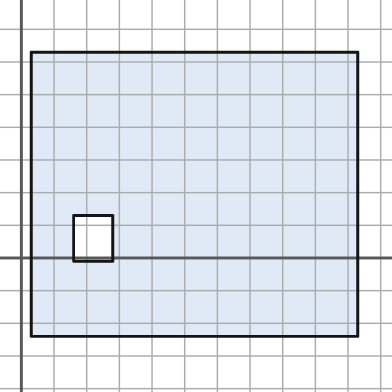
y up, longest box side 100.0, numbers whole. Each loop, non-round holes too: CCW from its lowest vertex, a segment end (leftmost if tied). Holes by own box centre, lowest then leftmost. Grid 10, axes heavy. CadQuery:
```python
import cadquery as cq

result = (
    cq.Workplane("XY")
    .moveTo(3.0, -24.0)
    .lineTo(103.0, -24.0)
    .lineTo(103.0, 63.0)
    .lineTo(3.0, 63.0)
    .close()
    .moveTo(16.0, -1.0)
    .lineTo(28.0, -1.0)
    .lineTo(28.0, 13.0)
    .lineTo(16.0, 13.0)
    .close()
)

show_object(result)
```